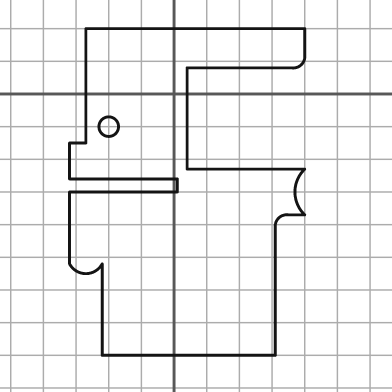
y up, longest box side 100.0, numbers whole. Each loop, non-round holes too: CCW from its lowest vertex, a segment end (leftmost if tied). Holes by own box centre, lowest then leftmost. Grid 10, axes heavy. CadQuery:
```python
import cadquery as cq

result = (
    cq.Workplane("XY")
    .moveTo(-22.0, -80.0)
    .lineTo(31.0, -80.0)
    .lineTo(31.0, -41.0)
    .threePointArc((32.0, -38.0), (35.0, -37.0))
    .lineTo(40.0, -37.0)
    .threePointArc((37.0, -30.0), (40.0, -23.0))
    .lineTo(4.0, -23.0)
    .lineTo(4.0, 8.0)
    .lineTo(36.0, 8.0)
    .threePointArc((39.0, 9.0), (40.0, 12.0))
    .lineTo(40.0, 20.0)
    .lineTo(-27.0, 20.0)
    .lineTo(-27.0, -15.0)
    .lineTo(-32.0, -15.0)
    .lineTo(-32.0, -26.0)
    .lineTo(1.0, -26.0)
    .lineTo(1.0, -30.0)
    .lineTo(-32.0, -30.0)
    .lineTo(-32.0, -52.0)
    .threePointArc((-27.0, -55.0), (-22.0, -52.0))
    .close()
    .moveTo(-20.0, -10.0)
    .circle(3.0)
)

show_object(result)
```